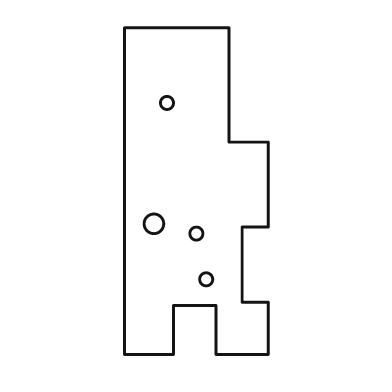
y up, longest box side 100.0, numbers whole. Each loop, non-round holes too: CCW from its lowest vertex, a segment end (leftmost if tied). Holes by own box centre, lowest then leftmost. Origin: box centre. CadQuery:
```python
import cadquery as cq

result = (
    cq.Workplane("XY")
    .moveTo(-22.0, -50.0)
    .lineTo(-7.0, -50.0)
    .lineTo(-7.0, -35.0)
    .lineTo(6.0, -35.0)
    .lineTo(6.0, -50.0)
    .lineTo(22.0, -50.0)
    .lineTo(22.0, -34.0)
    .lineTo(14.0, -34.0)
    .lineTo(14.0, -11.0)
    .lineTo(22.0, -11.0)
    .lineTo(22.0, 15.0)
    .lineTo(10.0, 15.0)
    .lineTo(10.0, 50.0)
    .lineTo(-22.0, 50.0)
    .close()
    .moveTo(3.0, -27.0)
    .circle(2.0)
    .moveTo(0.0, -13.0)
    .circle(2.0)
    .moveTo(-13.0, -10.0)
    .circle(3.0)
    .moveTo(-9.0, 27.0)
    .circle(2.0)
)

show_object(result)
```